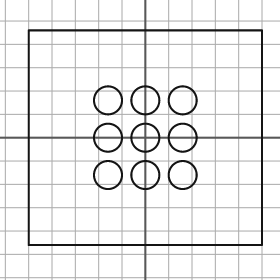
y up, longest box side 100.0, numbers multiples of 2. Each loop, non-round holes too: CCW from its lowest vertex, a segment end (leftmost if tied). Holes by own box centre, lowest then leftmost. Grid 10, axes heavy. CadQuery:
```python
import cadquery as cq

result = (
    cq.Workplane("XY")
    .moveTo(-50.0, -46.0)
    .lineTo(50.0, -46.0)
    .lineTo(50.0, 46.0)
    .lineTo(-50.0, 46.0)
    .close()
    .moveTo(-16.0, -16.0)
    .circle(6.0)
    .moveTo(0.0, -16.0)
    .circle(6.0)
    .moveTo(16.0, -16.0)
    .circle(6.0)
    .moveTo(-16.0, 0.0)
    .circle(6.0)
    .moveTo(0.0, 0.0)
    .circle(6.0)
    .moveTo(16.0, 0.0)
    .circle(6.0)
    .moveTo(-16.0, 16.0)
    .circle(6.0)
    .moveTo(0.0, 16.0)
    .circle(6.0)
    .moveTo(16.0, 16.0)
    .circle(6.0)
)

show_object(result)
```